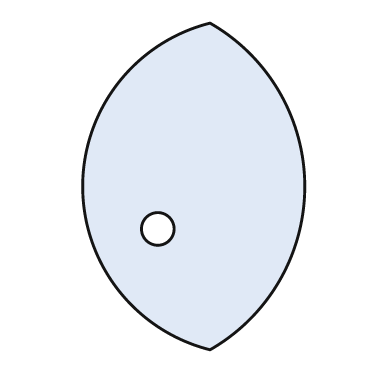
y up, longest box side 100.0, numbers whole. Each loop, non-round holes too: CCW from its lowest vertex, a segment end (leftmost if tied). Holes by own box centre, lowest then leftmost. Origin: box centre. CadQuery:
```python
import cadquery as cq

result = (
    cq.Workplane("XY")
    .moveTo(5.0, -50.0)
    .threePointArc((34.0, 0.0), (5.0, 50.0))
    .threePointArc((-34.0, 0.0), (5.0, -50.0))
    .close()
    .moveTo(-11.0, -13.0)
    .circle(5.0)
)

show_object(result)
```